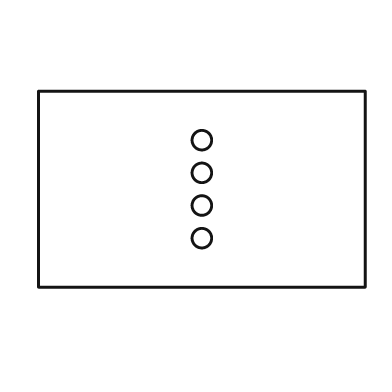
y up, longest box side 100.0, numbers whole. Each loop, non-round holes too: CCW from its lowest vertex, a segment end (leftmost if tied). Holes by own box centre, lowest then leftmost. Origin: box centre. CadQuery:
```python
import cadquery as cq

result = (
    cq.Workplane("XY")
    .moveTo(-50.0, -30.0)
    .lineTo(50.0, -30.0)
    .lineTo(50.0, 30.0)
    .lineTo(-50.0, 30.0)
    .close()
    .moveTo(0.0, -15.0)
    .circle(3.0)
    .moveTo(0.0, -5.0)
    .circle(3.0)
    .moveTo(0.0, 5.0)
    .circle(3.0)
    .moveTo(0.0, 15.0)
    .circle(3.0)
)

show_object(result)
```